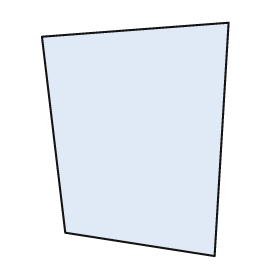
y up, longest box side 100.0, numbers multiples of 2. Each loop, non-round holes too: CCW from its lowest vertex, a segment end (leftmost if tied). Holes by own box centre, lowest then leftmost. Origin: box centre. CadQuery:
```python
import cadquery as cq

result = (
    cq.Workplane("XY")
    .moveTo(34.0, -50.0)
    .lineTo(40.0, 50.0)
    .lineTo(-40.0, 44.0)
    .lineTo(-30.0, -40.0)
    .close()
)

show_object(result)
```